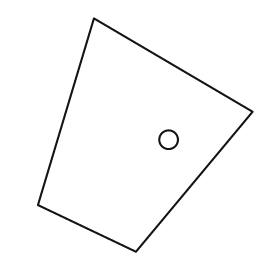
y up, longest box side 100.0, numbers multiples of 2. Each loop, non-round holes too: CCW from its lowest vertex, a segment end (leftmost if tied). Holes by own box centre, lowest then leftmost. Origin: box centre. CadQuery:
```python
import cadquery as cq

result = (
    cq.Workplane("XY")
    .moveTo(-4.0, -50.0)
    .lineTo(46.0, 10.0)
    .lineTo(-22.0, 50.0)
    .lineTo(-46.0, -30.0)
    .close()
    .moveTo(10.0, -2.0)
    .circle(4.0)
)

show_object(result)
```